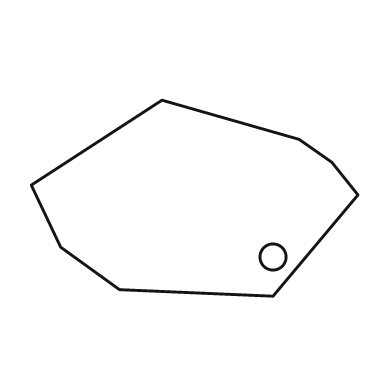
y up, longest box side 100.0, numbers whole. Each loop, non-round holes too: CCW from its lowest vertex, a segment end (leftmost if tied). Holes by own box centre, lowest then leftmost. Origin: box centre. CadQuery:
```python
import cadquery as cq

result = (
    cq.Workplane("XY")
    .moveTo(24.0, -30.0)
    .lineTo(50.0, 1.0)
    .lineTo(42.0, 11.0)
    .lineTo(32.0, 18.0)
    .lineTo(-10.0, 30.0)
    .lineTo(-50.0, 4.0)
    .lineTo(-41.0, -15.0)
    .lineTo(-23.0, -28.0)
    .close()
    .moveTo(24.0, -18.0)
    .circle(4.0)
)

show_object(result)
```